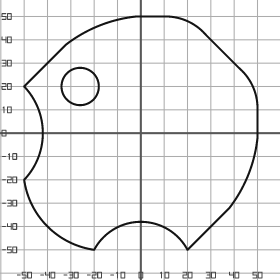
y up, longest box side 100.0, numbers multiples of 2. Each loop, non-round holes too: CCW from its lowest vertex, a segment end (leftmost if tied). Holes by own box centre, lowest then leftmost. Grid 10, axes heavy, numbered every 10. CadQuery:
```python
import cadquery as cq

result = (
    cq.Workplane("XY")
    .moveTo(-20.0, -50.0)
    .threePointArc((0.0, -38.0), (20.0, -50.0))
    .lineTo(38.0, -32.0)
    .threePointArc((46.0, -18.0), (50.0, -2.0))
    .lineTo(50.0, 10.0)
    .threePointArc((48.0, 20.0), (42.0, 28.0))
    .lineTo(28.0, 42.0)
    .threePointArc((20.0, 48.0), (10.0, 50.0))
    .lineTo(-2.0, 50.0)
    .threePointArc((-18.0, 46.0), (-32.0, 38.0))
    .lineTo(-50.0, 20.0)
    .threePointArc((-42.0, 0.0), (-50.0, -20.0))
    .threePointArc((-40.0, -40.0), (-20.0, -50.0))
    .close()
    .moveTo(-26.0, 20.0)
    .circle(8.0)
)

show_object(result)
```